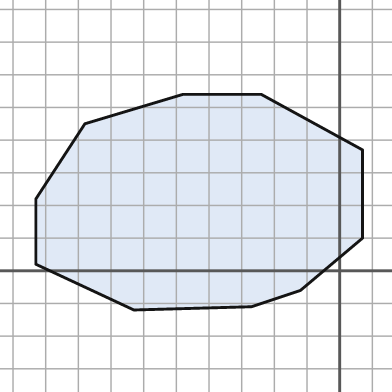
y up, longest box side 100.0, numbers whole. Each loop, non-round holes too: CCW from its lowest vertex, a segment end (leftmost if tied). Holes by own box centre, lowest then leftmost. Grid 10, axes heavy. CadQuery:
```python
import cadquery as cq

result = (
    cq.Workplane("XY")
    .moveTo(-63.0, -12.0)
    .lineTo(-27.0, -11.0)
    .lineTo(-12.0, -6.0)
    .lineTo(7.0, 10.0)
    .lineTo(7.0, 37.0)
    .lineTo(-24.0, 54.0)
    .lineTo(-48.0, 54.0)
    .lineTo(-78.0, 45.0)
    .lineTo(-93.0, 22.0)
    .lineTo(-93.0, 2.0)
    .close()
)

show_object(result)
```